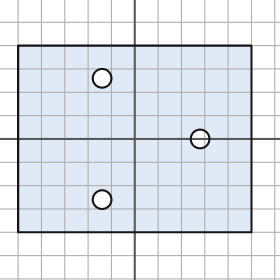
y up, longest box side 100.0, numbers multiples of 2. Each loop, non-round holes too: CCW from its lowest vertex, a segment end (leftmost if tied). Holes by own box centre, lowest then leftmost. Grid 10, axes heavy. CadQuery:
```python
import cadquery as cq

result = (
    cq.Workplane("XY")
    .moveTo(-50.0, -40.0)
    .lineTo(50.0, -40.0)
    .lineTo(50.0, 40.0)
    .lineTo(-50.0, 40.0)
    .close()
    .moveTo(-14.0, -26.0)
    .circle(4.0)
    .moveTo(28.0, 0.0)
    .circle(4.0)
    .moveTo(-14.0, 26.0)
    .circle(4.0)
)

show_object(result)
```